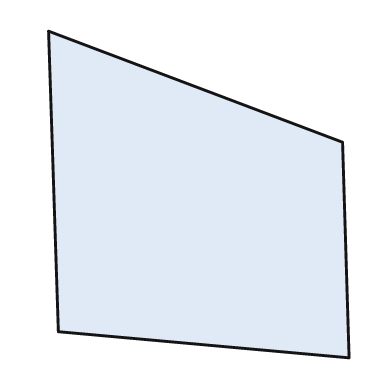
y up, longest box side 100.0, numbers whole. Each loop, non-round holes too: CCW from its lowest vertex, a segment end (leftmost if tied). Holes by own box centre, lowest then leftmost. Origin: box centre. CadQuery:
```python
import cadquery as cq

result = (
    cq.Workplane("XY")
    .moveTo(46.0, -50.0)
    .lineTo(44.0, 16.0)
    .lineTo(-46.0, 50.0)
    .lineTo(-43.0, -42.0)
    .close()
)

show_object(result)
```